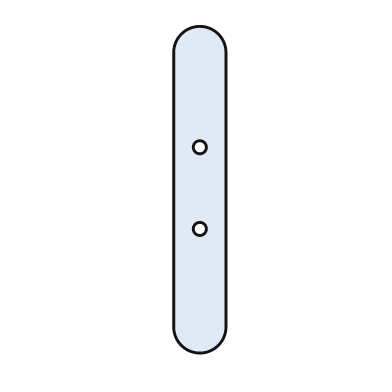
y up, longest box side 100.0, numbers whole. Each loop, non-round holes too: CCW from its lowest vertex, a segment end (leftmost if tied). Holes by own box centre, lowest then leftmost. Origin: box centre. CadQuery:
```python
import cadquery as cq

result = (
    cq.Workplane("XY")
    .moveTo(-8.0, -42.0)
    .threePointArc((0.0, -50.0), (8.0, -42.0))
    .lineTo(8.0, 42.0)
    .threePointArc((0.0, 50.0), (-8.0, 42.0))
    .close()
    .moveTo(0.0, -12.0)
    .circle(2.0)
    .moveTo(0.0, 13.0)
    .circle(2.0)
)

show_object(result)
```